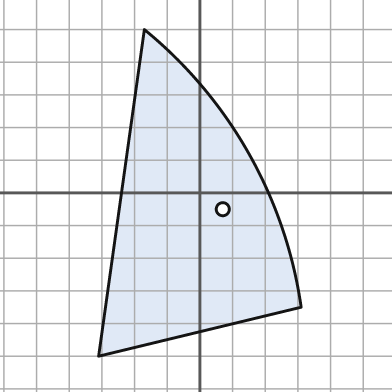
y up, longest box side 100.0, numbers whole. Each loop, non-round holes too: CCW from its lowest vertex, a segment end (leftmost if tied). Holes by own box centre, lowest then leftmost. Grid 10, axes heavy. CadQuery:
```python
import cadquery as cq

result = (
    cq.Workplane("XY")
    .moveTo(-31.0, -50.0)
    .lineTo(31.0, -35.0)
    .threePointArc((15.0, 12.0), (-17.0, 50.0))
    .close()
    .moveTo(7.0, -5.0)
    .circle(2.0)
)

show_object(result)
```